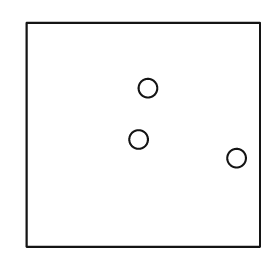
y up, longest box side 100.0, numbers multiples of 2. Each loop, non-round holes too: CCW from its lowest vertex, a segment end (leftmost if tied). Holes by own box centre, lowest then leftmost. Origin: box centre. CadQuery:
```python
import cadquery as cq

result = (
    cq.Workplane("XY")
    .moveTo(-50.0, -48.0)
    .lineTo(50.0, -48.0)
    .lineTo(50.0, 48.0)
    .lineTo(-50.0, 48.0)
    .close()
    .moveTo(40.0, -10.0)
    .circle(4.0)
    .moveTo(-2.0, -2.0)
    .circle(4.0)
    .moveTo(2.0, 20.0)
    .circle(4.0)
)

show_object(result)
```